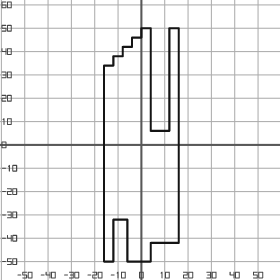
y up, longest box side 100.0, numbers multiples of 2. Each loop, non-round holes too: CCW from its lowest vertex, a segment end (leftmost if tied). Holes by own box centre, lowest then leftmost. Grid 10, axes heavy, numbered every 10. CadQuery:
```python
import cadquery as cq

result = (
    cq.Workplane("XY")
    .moveTo(-16.0, -50.0)
    .lineTo(-12.0, -50.0)
    .lineTo(-12.0, -32.0)
    .lineTo(-6.0, -32.0)
    .lineTo(-6.0, -50.0)
    .lineTo(4.0, -50.0)
    .lineTo(4.0, -42.0)
    .lineTo(16.0, -42.0)
    .lineTo(16.0, 50.0)
    .lineTo(12.0, 50.0)
    .lineTo(12.0, 6.0)
    .lineTo(4.0, 6.0)
    .lineTo(4.0, 50.0)
    .lineTo(0.0, 50.0)
    .lineTo(0.0, 46.0)
    .lineTo(-4.0, 46.0)
    .lineTo(-4.0, 42.0)
    .lineTo(-8.0, 42.0)
    .lineTo(-8.0, 38.0)
    .lineTo(-12.0, 38.0)
    .lineTo(-12.0, 34.0)
    .lineTo(-16.0, 34.0)
    .close()
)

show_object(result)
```